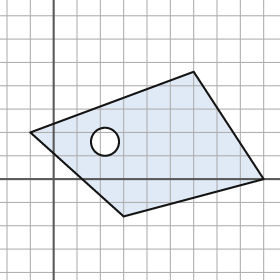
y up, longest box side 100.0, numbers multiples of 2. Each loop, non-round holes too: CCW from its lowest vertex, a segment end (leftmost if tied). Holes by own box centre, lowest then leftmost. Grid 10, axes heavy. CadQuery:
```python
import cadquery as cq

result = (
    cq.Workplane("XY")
    .moveTo(30.0, -16.0)
    .lineTo(90.0, 0.0)
    .lineTo(60.0, 46.0)
    .lineTo(-10.0, 20.0)
    .close()
    .moveTo(22.0, 16.0)
    .circle(6.0)
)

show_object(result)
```